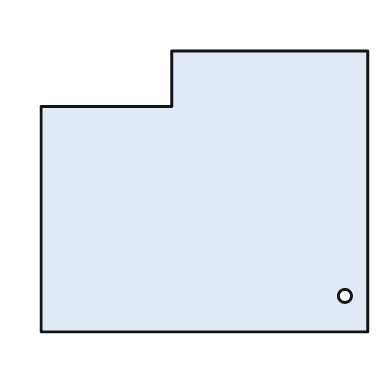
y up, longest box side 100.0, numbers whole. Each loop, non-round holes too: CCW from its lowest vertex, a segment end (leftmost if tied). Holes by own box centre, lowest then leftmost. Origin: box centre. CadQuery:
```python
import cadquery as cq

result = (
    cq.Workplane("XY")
    .moveTo(-50.0, -43.0)
    .lineTo(50.0, -43.0)
    .lineTo(50.0, 43.0)
    .lineTo(-10.0, 43.0)
    .lineTo(-10.0, 26.0)
    .lineTo(-50.0, 26.0)
    .close()
    .moveTo(43.0, -32.0)
    .circle(2.0)
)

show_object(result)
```